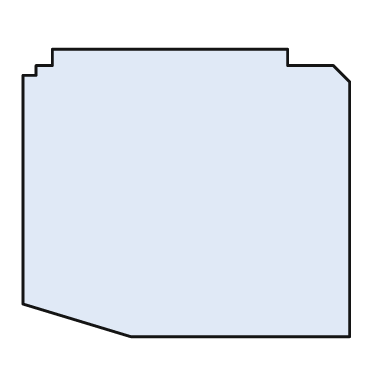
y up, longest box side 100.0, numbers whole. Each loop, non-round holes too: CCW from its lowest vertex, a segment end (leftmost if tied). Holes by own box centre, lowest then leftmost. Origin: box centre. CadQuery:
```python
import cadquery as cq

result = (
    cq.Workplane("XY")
    .moveTo(-17.0, -44.0)
    .lineTo(50.0, -44.0)
    .lineTo(50.0, 34.0)
    .lineTo(45.0, 39.0)
    .lineTo(31.0, 39.0)
    .lineTo(31.0, 44.0)
    .lineTo(-41.0, 44.0)
    .lineTo(-41.0, 39.0)
    .lineTo(-46.0, 39.0)
    .lineTo(-46.0, 36.0)
    .lineTo(-50.0, 36.0)
    .lineTo(-50.0, -34.0)
    .close()
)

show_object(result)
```